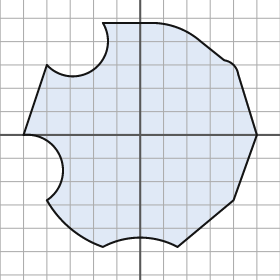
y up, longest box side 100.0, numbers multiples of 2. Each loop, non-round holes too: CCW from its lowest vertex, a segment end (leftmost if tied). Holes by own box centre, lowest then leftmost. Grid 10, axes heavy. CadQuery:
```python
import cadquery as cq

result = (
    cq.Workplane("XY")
    .moveTo(-16.0, -48.0)
    .threePointArc((0.0, -44.0), (16.0, -48.0))
    .lineTo(40.0, -28.0)
    .lineTo(50.0, 0.0)
    .lineTo(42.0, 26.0)
    .threePointArc((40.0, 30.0), (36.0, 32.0))
    .lineTo(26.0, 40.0)
    .threePointArc((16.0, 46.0), (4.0, 48.0))
    .lineTo(-16.0, 48.0)
    .threePointArc((-20.0, 28.0), (-40.0, 30.0))
    .lineTo(-50.0, 0.0)
    .threePointArc((-34.0, -10.0), (-40.0, -28.0))
    .threePointArc((-30.0, -40.0), (-16.0, -48.0))
    .close()
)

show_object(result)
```